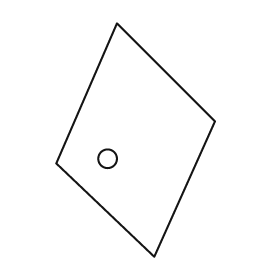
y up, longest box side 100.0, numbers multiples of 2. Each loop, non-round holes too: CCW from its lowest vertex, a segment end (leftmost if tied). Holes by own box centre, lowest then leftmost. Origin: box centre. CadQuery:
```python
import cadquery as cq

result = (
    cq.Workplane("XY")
    .moveTo(8.0, -50.0)
    .lineTo(34.0, 8.0)
    .lineTo(-8.0, 50.0)
    .lineTo(-34.0, -10.0)
    .close()
    .moveTo(-12.0, -8.0)
    .circle(4.0)
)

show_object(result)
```